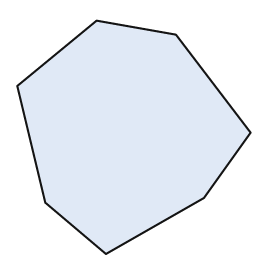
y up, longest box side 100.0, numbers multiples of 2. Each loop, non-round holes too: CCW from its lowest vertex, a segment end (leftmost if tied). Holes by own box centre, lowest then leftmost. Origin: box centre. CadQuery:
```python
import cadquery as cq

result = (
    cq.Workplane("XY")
    .moveTo(-12.0, -50.0)
    .lineTo(30.0, -26.0)
    .lineTo(50.0, 2.0)
    .lineTo(18.0, 44.0)
    .lineTo(-16.0, 50.0)
    .lineTo(-50.0, 22.0)
    .lineTo(-38.0, -28.0)
    .close()
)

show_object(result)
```